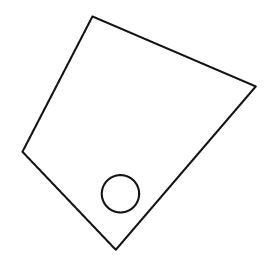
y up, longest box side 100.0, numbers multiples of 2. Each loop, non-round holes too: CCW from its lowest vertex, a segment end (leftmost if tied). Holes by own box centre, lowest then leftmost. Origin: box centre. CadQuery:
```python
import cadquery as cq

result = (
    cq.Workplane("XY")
    .moveTo(-10.0, -50.0)
    .lineTo(50.0, 20.0)
    .lineTo(-20.0, 50.0)
    .lineTo(-50.0, -8.0)
    .close()
    .moveTo(-8.0, -26.0)
    .circle(8.0)
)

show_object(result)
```